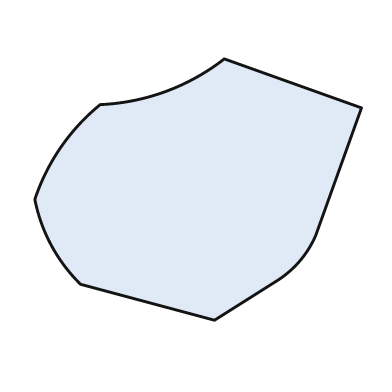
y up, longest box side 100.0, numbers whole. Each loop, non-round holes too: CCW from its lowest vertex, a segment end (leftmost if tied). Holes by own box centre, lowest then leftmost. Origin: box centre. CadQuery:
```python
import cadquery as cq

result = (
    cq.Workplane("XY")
    .moveTo(5.0, -40.0)
    .lineTo(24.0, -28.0)
    .threePointArc((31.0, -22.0), (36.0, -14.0))
    .lineTo(50.0, 25.0)
    .lineTo(8.0, 40.0)
    .threePointArc((-10.0, 30.0), (-30.0, 26.0))
    .threePointArc((-42.0, 13.0), (-50.0, -3.0))
    .threePointArc((-45.0, -17.0), (-36.0, -29.0))
    .close()
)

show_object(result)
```